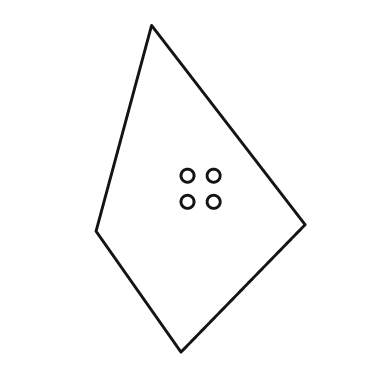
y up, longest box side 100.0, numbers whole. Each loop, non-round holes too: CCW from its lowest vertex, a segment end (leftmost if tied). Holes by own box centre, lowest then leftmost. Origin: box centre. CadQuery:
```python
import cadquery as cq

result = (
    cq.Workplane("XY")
    .moveTo(-6.0, -50.0)
    .lineTo(32.0, -11.0)
    .lineTo(-15.0, 50.0)
    .lineTo(-32.0, -13.0)
    .close()
    .moveTo(-4.0, -4.0)
    .circle(2.0)
    .moveTo(4.0, -4.0)
    .circle(2.0)
    .moveTo(-4.0, 4.0)
    .circle(2.0)
    .moveTo(4.0, 4.0)
    .circle(2.0)
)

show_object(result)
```